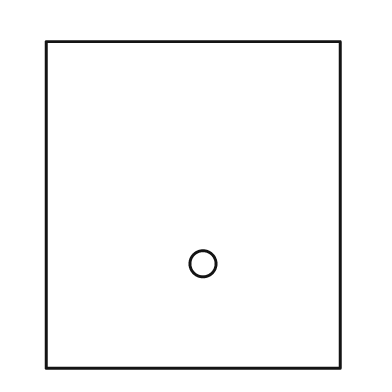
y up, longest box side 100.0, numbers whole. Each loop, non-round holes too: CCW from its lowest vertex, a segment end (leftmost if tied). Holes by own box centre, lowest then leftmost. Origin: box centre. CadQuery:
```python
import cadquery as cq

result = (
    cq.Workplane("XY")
    .moveTo(-45.0, -50.0)
    .lineTo(45.0, -50.0)
    .lineTo(45.0, 50.0)
    .lineTo(-45.0, 50.0)
    .close()
    .moveTo(3.0, -18.0)
    .circle(4.0)
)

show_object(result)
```